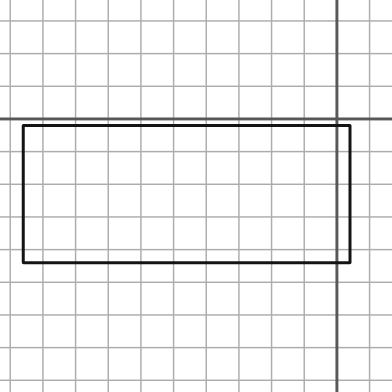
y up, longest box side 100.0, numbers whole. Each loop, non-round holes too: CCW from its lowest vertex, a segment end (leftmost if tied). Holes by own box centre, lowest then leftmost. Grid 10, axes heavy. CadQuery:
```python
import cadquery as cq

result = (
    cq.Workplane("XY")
    .moveTo(-96.0, -44.0)
    .lineTo(4.0, -44.0)
    .lineTo(4.0, -2.0)
    .lineTo(-96.0, -2.0)
    .close()
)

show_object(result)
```